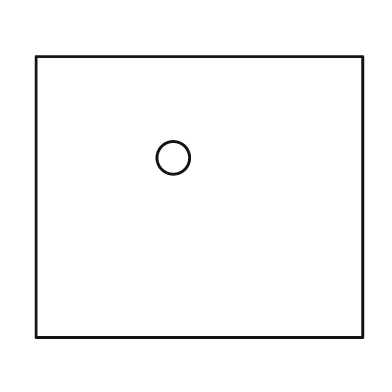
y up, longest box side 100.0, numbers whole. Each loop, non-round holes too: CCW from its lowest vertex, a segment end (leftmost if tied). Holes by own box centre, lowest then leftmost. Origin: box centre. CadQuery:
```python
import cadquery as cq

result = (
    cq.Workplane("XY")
    .moveTo(-50.0, -43.0)
    .lineTo(50.0, -43.0)
    .lineTo(50.0, 43.0)
    .lineTo(-50.0, 43.0)
    .close()
    .moveTo(-8.0, 12.0)
    .circle(5.0)
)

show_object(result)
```